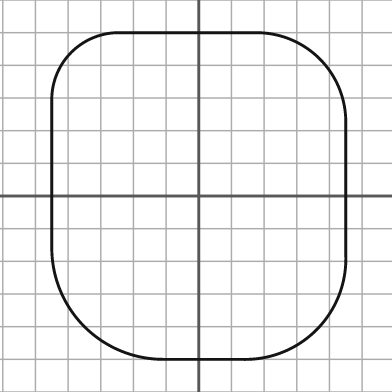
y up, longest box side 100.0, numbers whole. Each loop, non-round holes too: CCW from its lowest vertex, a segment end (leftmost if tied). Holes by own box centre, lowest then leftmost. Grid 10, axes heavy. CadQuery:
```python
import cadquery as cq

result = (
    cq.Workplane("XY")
    .moveTo(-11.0, -50.0)
    .lineTo(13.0, -50.0)
    .threePointArc((36.0, -41.0), (45.0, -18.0))
    .lineTo(45.0, 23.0)
    .threePointArc((37.0, 42.0), (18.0, 50.0))
    .lineTo(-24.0, 50.0)
    .threePointArc((-39.0, 44.0), (-45.0, 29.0))
    .lineTo(-45.0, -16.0)
    .threePointArc((-35.0, -40.0), (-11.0, -50.0))
    .close()
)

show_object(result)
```